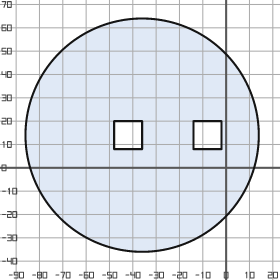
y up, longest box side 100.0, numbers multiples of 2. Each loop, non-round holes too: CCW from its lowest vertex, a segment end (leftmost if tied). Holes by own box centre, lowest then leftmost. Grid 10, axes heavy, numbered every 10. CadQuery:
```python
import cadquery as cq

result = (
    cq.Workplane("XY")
    .moveTo(-36.0, 14.0)
    .circle(50.0)
    .moveTo(-48.0, 8.0)
    .lineTo(-36.0, 8.0)
    .lineTo(-36.0, 20.0)
    .lineTo(-48.0, 20.0)
    .close()
    .moveTo(-14.0, 8.0)
    .lineTo(-2.0, 8.0)
    .lineTo(-2.0, 20.0)
    .lineTo(-14.0, 20.0)
    .close()
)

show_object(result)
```